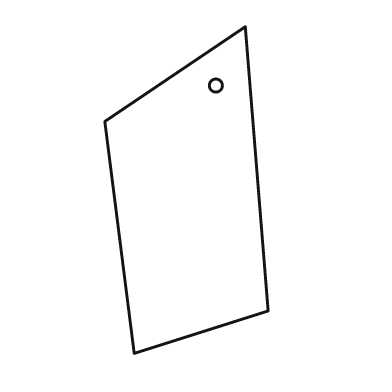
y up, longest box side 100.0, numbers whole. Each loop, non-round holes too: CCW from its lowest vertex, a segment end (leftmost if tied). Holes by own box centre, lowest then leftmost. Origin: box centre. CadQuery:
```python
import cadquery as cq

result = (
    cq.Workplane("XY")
    .moveTo(-16.0, -50.0)
    .lineTo(25.0, -37.0)
    .lineTo(18.0, 50.0)
    .lineTo(-25.0, 21.0)
    .close()
    .moveTo(9.0, 32.0)
    .circle(2.0)
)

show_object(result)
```